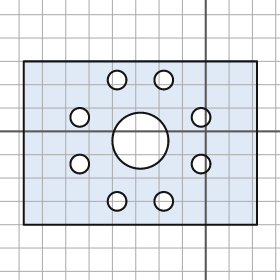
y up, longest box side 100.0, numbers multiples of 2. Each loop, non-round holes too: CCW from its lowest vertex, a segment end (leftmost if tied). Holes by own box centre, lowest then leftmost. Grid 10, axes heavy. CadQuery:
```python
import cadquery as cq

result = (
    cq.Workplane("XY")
    .moveTo(-78.0, -40.0)
    .lineTo(22.0, -40.0)
    .lineTo(22.0, 30.0)
    .lineTo(-78.0, 30.0)
    .close()
    .moveTo(-38.0, -30.0)
    .circle(4.0)
    .moveTo(-18.0, -30.0)
    .circle(4.0)
    .moveTo(-54.0, -14.0)
    .circle(4.0)
    .moveTo(-2.0, -14.0)
    .circle(4.0)
    .moveTo(-28.0, -4.0)
    .circle(12.0)
    .moveTo(-54.0, 6.0)
    .circle(4.0)
    .moveTo(-2.0, 6.0)
    .circle(4.0)
    .moveTo(-38.0, 22.0)
    .circle(4.0)
    .moveTo(-18.0, 22.0)
    .circle(4.0)
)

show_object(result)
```